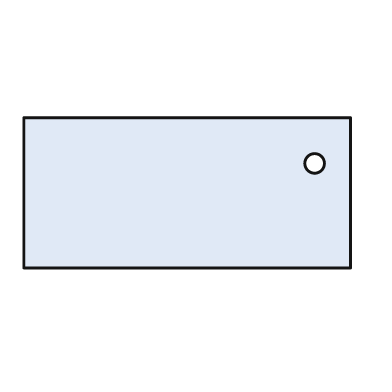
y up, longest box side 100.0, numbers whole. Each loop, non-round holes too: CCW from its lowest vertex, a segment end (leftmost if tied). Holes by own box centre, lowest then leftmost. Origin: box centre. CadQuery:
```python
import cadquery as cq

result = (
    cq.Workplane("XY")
    .moveTo(-50.0, -23.0)
    .lineTo(50.0, -23.0)
    .lineTo(50.0, 23.0)
    .lineTo(-50.0, 23.0)
    .close()
    .moveTo(39.0, 9.0)
    .circle(3.0)
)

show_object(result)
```